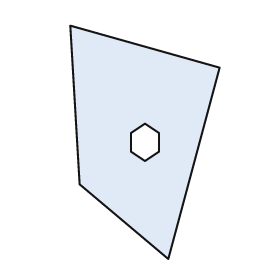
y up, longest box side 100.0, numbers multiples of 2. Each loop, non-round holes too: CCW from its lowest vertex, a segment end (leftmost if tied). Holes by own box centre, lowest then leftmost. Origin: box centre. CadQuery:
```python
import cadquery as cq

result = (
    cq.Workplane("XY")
    .moveTo(10.0, -50.0)
    .lineTo(32.0, 32.0)
    .lineTo(-32.0, 50.0)
    .lineTo(-28.0, -18.0)
    .close()
    .moveTo(0.0, -8.0)
    .lineTo(6.0, -4.0)
    .lineTo(6.0, 4.0)
    .lineTo(0.0, 8.0)
    .lineTo(-6.0, 4.0)
    .lineTo(-6.0, -4.0)
    .close()
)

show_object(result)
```